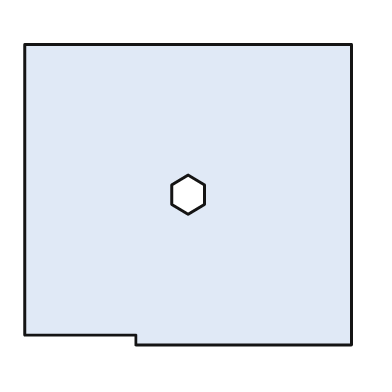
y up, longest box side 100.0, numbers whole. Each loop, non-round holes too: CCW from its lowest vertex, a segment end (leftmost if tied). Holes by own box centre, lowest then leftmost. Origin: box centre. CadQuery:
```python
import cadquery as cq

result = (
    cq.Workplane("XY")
    .moveTo(-16.0, -46.0)
    .lineTo(50.0, -46.0)
    .lineTo(50.0, 46.0)
    .lineTo(-50.0, 46.0)
    .lineTo(-50.0, -43.0)
    .lineTo(-16.0, -43.0)
    .close()
    .moveTo(0.0, -6.0)
    .lineTo(5.0, -3.0)
    .lineTo(5.0, 3.0)
    .lineTo(0.0, 6.0)
    .lineTo(-5.0, 3.0)
    .lineTo(-5.0, -3.0)
    .close()
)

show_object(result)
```